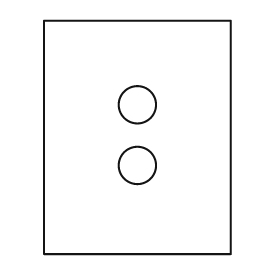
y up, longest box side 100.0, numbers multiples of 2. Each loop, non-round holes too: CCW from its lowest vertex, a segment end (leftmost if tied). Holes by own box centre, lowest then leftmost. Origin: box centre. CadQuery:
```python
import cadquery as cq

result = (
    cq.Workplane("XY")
    .moveTo(-40.0, -50.0)
    .lineTo(40.0, -50.0)
    .lineTo(40.0, 50.0)
    .lineTo(-40.0, 50.0)
    .close()
    .moveTo(0.0, -12.0)
    .circle(8.0)
    .moveTo(0.0, 14.0)
    .circle(8.0)
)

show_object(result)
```